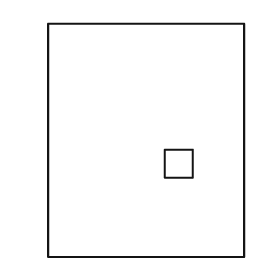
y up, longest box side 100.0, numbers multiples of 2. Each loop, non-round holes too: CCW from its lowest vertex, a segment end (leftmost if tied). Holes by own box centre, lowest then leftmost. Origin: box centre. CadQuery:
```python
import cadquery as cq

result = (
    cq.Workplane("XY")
    .moveTo(-42.0, -50.0)
    .lineTo(42.0, -50.0)
    .lineTo(42.0, 50.0)
    .lineTo(-42.0, 50.0)
    .close()
    .moveTo(8.0, -16.0)
    .lineTo(20.0, -16.0)
    .lineTo(20.0, -4.0)
    .lineTo(8.0, -4.0)
    .close()
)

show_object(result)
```